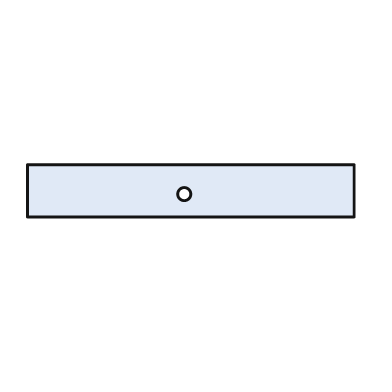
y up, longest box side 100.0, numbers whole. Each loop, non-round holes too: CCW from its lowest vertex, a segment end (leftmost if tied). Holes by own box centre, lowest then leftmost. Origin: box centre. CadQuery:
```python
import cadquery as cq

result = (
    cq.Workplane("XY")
    .moveTo(-50.0, -8.0)
    .lineTo(50.0, -8.0)
    .lineTo(50.0, 8.0)
    .lineTo(-50.0, 8.0)
    .close()
    .moveTo(-2.0, -1.0)
    .circle(2.0)
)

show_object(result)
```